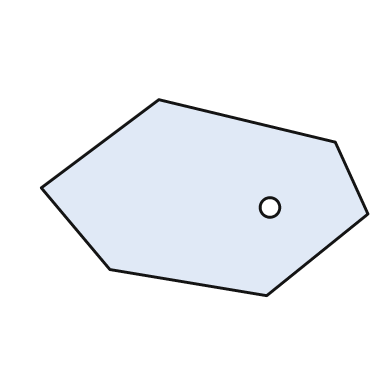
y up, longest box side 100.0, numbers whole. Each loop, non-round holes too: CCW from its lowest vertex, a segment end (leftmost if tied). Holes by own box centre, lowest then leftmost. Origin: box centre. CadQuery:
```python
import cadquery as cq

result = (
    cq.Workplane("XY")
    .moveTo(19.0, -30.0)
    .lineTo(50.0, -5.0)
    .lineTo(40.0, 17.0)
    .lineTo(-14.0, 30.0)
    .lineTo(-50.0, 3.0)
    .lineTo(-29.0, -22.0)
    .close()
    .moveTo(20.0, -3.0)
    .circle(3.0)
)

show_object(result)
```